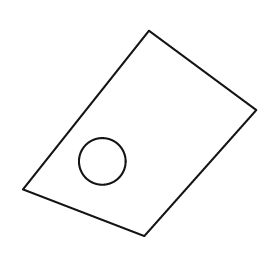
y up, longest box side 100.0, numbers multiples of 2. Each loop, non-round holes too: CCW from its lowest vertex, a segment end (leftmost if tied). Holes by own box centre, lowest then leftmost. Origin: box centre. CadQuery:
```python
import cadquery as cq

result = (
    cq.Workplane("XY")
    .moveTo(2.0, -44.0)
    .lineTo(50.0, 10.0)
    .lineTo(4.0, 44.0)
    .lineTo(-50.0, -24.0)
    .close()
    .moveTo(-16.0, -12.0)
    .circle(10.0)
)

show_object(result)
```